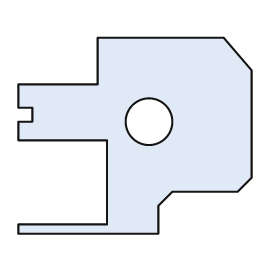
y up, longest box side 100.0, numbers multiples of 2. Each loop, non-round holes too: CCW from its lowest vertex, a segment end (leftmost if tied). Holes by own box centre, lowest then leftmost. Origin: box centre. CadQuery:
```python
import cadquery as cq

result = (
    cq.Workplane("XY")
    .moveTo(-50.0, -42.0)
    .lineTo(10.0, -42.0)
    .lineTo(10.0, -30.0)
    .lineTo(16.0, -24.0)
    .lineTo(44.0, -24.0)
    .lineTo(50.0, -18.0)
    .lineTo(50.0, 28.0)
    .lineTo(38.0, 42.0)
    .lineTo(-16.0, 42.0)
    .lineTo(-16.0, 22.0)
    .lineTo(-50.0, 22.0)
    .lineTo(-50.0, 12.0)
    .lineTo(-44.0, 12.0)
    .lineTo(-44.0, 6.0)
    .lineTo(-50.0, 6.0)
    .lineTo(-50.0, -2.0)
    .lineTo(-12.0, -2.0)
    .lineTo(-12.0, -38.0)
    .lineTo(-50.0, -38.0)
    .close()
    .moveTo(6.0, 6.0)
    .circle(10.0)
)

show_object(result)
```